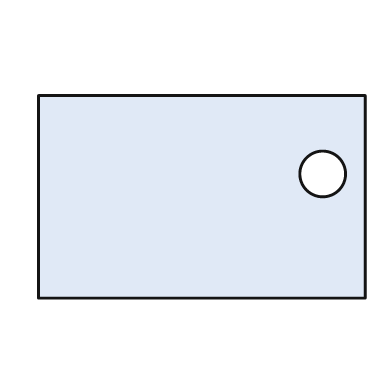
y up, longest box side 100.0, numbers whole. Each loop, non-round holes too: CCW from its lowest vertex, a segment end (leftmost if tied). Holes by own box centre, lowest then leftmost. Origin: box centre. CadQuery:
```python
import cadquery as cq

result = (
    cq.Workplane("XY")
    .moveTo(-50.0, -31.0)
    .lineTo(50.0, -31.0)
    .lineTo(50.0, 31.0)
    .lineTo(-50.0, 31.0)
    .close()
    .moveTo(37.0, 7.0)
    .circle(7.0)
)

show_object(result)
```